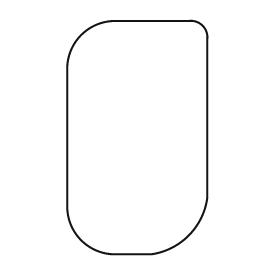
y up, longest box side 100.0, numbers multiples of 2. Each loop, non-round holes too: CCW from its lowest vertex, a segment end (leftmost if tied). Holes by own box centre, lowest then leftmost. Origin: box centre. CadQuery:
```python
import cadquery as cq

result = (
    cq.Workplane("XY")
    .moveTo(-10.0, -50.0)
    .lineTo(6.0, -50.0)
    .threePointArc((22.0, -42.0), (30.0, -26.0))
    .lineTo(30.0, 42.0)
    .threePointArc((28.0, 48.0), (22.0, 50.0))
    .lineTo(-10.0, 50.0)
    .threePointArc((-24.0, 44.0), (-30.0, 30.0))
    .lineTo(-30.0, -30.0)
    .threePointArc((-24.0, -44.0), (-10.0, -50.0))
    .close()
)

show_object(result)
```